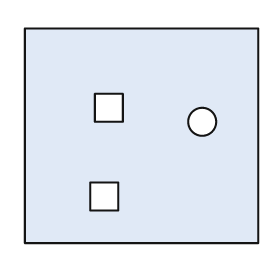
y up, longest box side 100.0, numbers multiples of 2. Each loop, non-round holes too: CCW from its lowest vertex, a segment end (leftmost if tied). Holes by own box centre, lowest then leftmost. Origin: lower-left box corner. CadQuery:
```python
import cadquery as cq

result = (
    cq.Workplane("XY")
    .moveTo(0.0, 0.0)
    .lineTo(100.0, 0.0)
    .lineTo(100.0, 92.0)
    .lineTo(0.0, 92.0)
    .close()
    .moveTo(28.0, 14.0)
    .lineTo(40.0, 14.0)
    .lineTo(40.0, 26.0)
    .lineTo(28.0, 26.0)
    .close()
    .moveTo(76.0, 52.0)
    .circle(6.0)
    .moveTo(30.0, 52.0)
    .lineTo(42.0, 52.0)
    .lineTo(42.0, 64.0)
    .lineTo(30.0, 64.0)
    .close()
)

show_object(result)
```